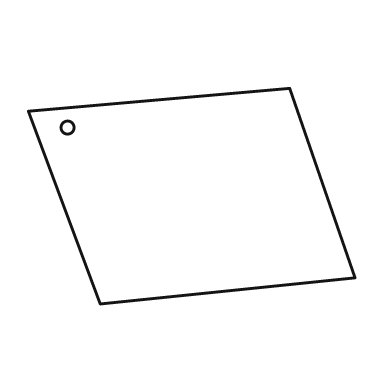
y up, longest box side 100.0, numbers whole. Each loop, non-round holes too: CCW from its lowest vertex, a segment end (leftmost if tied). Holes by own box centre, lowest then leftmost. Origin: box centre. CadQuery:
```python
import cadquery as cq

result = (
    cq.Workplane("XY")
    .moveTo(-28.0, -33.0)
    .lineTo(50.0, -25.0)
    .lineTo(30.0, 33.0)
    .lineTo(-50.0, 26.0)
    .close()
    .moveTo(-38.0, 21.0)
    .circle(2.0)
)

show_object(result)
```